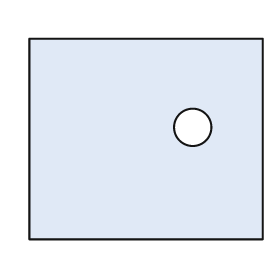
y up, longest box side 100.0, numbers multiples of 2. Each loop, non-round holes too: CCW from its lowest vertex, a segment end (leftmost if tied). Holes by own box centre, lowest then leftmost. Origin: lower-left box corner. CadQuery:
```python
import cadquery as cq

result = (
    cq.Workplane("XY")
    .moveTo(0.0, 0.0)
    .lineTo(100.0, 0.0)
    .lineTo(100.0, 86.0)
    .lineTo(0.0, 86.0)
    .close()
    .moveTo(70.0, 48.0)
    .circle(8.0)
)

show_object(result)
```